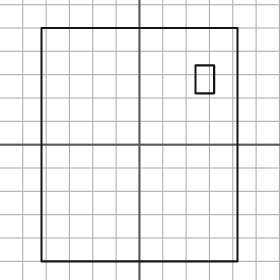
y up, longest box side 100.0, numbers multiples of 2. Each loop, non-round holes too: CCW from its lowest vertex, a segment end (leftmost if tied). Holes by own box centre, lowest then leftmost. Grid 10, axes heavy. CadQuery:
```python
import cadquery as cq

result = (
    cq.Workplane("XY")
    .moveTo(-42.0, -50.0)
    .lineTo(42.0, -50.0)
    .lineTo(42.0, 50.0)
    .lineTo(-42.0, 50.0)
    .close()
    .moveTo(24.0, 22.0)
    .lineTo(32.0, 22.0)
    .lineTo(32.0, 34.0)
    .lineTo(24.0, 34.0)
    .close()
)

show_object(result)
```